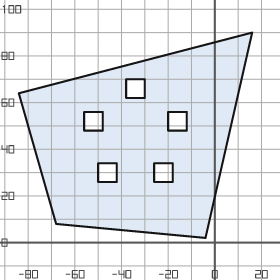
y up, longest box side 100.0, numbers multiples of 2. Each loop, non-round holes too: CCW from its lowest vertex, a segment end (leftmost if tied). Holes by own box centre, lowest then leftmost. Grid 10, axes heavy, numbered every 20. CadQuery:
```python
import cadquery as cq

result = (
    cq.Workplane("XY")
    .moveTo(-4.0, 2.0)
    .lineTo(16.0, 90.0)
    .lineTo(-84.0, 64.0)
    .lineTo(-68.0, 8.0)
    .close()
    .moveTo(-50.0, 26.0)
    .lineTo(-42.0, 26.0)
    .lineTo(-42.0, 34.0)
    .lineTo(-50.0, 34.0)
    .close()
    .moveTo(-26.0, 26.0)
    .lineTo(-18.0, 26.0)
    .lineTo(-18.0, 34.0)
    .lineTo(-26.0, 34.0)
    .close()
    .moveTo(-56.0, 48.0)
    .lineTo(-48.0, 48.0)
    .lineTo(-48.0, 56.0)
    .lineTo(-56.0, 56.0)
    .close()
    .moveTo(-20.0, 48.0)
    .lineTo(-12.0, 48.0)
    .lineTo(-12.0, 56.0)
    .lineTo(-20.0, 56.0)
    .close()
    .moveTo(-38.0, 62.0)
    .lineTo(-30.0, 62.0)
    .lineTo(-30.0, 70.0)
    .lineTo(-38.0, 70.0)
    .close()
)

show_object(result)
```